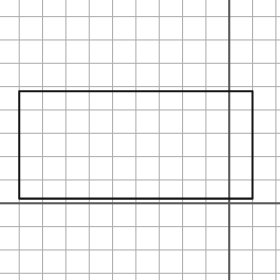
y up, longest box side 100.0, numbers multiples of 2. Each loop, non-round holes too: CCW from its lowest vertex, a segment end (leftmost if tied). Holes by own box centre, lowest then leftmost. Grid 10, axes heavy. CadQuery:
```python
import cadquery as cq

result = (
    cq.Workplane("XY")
    .moveTo(-90.0, 2.0)
    .lineTo(10.0, 2.0)
    .lineTo(10.0, 48.0)
    .lineTo(-90.0, 48.0)
    .close()
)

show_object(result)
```